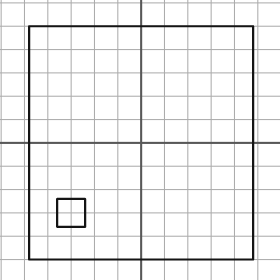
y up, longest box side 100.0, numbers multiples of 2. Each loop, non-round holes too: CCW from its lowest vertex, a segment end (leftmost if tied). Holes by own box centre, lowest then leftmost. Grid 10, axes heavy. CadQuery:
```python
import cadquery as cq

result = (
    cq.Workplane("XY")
    .moveTo(-48.0, -50.0)
    .lineTo(48.0, -50.0)
    .lineTo(48.0, 50.0)
    .lineTo(-48.0, 50.0)
    .close()
    .moveTo(-36.0, -36.0)
    .lineTo(-24.0, -36.0)
    .lineTo(-24.0, -24.0)
    .lineTo(-36.0, -24.0)
    .close()
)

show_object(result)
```